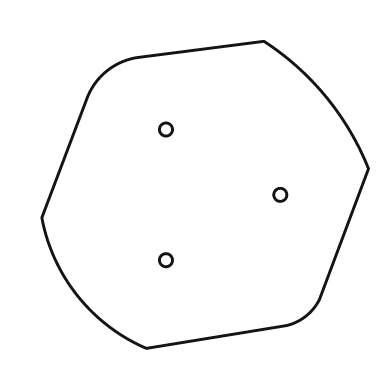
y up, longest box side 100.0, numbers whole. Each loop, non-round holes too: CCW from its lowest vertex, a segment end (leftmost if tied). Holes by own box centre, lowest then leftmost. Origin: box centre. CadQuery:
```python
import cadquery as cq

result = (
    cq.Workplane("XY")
    .moveTo(-18.0, -47.0)
    .lineTo(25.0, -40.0)
    .threePointArc((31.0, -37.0), (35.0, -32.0))
    .lineTo(50.0, 8.0)
    .threePointArc((37.0, 30.0), (18.0, 47.0))
    .lineTo(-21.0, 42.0)
    .threePointArc((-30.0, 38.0), (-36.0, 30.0))
    .lineTo(-50.0, -7.0)
    .threePointArc((-39.0, -31.0), (-18.0, -47.0))
    .close()
    .moveTo(-12.0, -20.0)
    .circle(2.0)
    .moveTo(23.0, 0.0)
    .circle(2.0)
    .moveTo(-12.0, 20.0)
    .circle(2.0)
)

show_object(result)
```